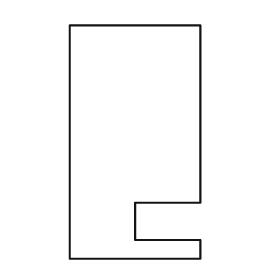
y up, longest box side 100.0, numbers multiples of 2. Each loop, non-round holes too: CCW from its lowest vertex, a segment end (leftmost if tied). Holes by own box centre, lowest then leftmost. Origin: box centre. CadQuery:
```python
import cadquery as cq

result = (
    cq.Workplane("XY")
    .moveTo(-28.0, -50.0)
    .lineTo(28.0, -50.0)
    .lineTo(28.0, -42.0)
    .lineTo(0.0, -42.0)
    .lineTo(0.0, -26.0)
    .lineTo(28.0, -26.0)
    .lineTo(28.0, 50.0)
    .lineTo(-28.0, 50.0)
    .close()
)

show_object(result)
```